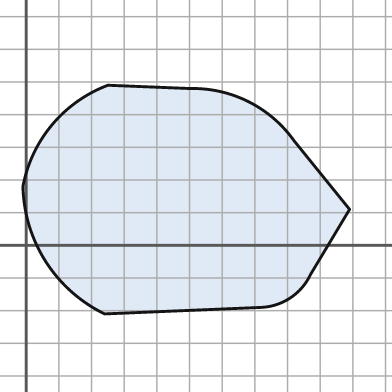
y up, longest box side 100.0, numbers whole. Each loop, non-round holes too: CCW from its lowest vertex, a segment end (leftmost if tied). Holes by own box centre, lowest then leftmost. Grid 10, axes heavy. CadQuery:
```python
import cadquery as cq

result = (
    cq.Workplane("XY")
    .moveTo(24.0, -21.0)
    .lineTo(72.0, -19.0)
    .threePointArc((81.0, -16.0), (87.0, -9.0))
    .lineTo(99.0, 11.0)
    .lineTo(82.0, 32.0)
    .threePointArc((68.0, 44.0), (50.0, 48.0))
    .lineTo(25.0, 49.0)
    .threePointArc((8.0, 37.0), (-1.0, 18.0))
    .threePointArc((6.0, -5.0), (24.0, -21.0))
    .close()
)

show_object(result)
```